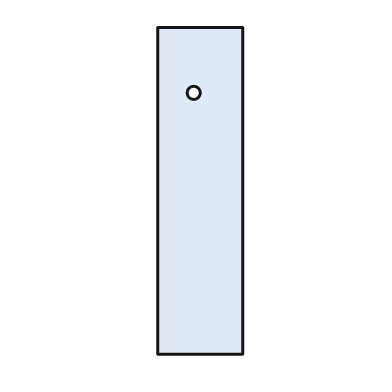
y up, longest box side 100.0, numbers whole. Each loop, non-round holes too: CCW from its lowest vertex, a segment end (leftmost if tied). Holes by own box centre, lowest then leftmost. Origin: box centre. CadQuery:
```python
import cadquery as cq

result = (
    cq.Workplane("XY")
    .moveTo(-13.0, -50.0)
    .lineTo(13.0, -50.0)
    .lineTo(13.0, 50.0)
    .lineTo(-13.0, 50.0)
    .close()
    .moveTo(-2.0, 30.0)
    .circle(2.0)
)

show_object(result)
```